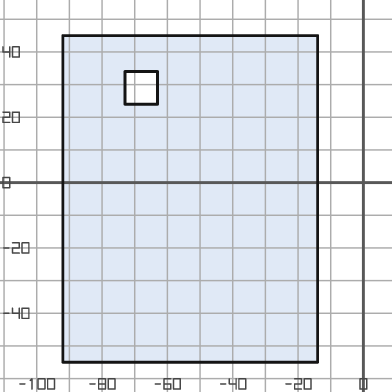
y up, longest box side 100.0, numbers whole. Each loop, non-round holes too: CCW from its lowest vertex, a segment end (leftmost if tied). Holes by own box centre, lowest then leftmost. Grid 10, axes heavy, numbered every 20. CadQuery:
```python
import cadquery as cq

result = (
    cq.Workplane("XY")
    .moveTo(-92.0, -55.0)
    .lineTo(-14.0, -55.0)
    .lineTo(-14.0, 45.0)
    .lineTo(-92.0, 45.0)
    .close()
    .moveTo(-73.0, 24.0)
    .lineTo(-63.0, 24.0)
    .lineTo(-63.0, 34.0)
    .lineTo(-73.0, 34.0)
    .close()
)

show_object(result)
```